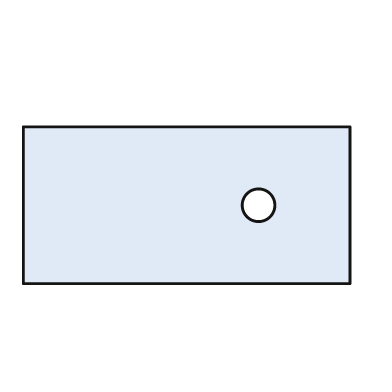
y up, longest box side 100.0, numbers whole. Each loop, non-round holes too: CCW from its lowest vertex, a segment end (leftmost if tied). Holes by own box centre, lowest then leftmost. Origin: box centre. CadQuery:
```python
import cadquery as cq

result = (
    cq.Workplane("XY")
    .moveTo(-50.0, -24.0)
    .lineTo(50.0, -24.0)
    .lineTo(50.0, 24.0)
    .lineTo(-50.0, 24.0)
    .close()
    .moveTo(22.0, 0.0)
    .circle(5.0)
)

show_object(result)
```